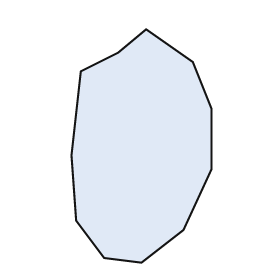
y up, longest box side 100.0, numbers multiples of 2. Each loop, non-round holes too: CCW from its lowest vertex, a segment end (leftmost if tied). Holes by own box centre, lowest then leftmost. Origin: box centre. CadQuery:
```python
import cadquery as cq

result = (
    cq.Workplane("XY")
    .moveTo(0.0, -50.0)
    .lineTo(18.0, -36.0)
    .lineTo(30.0, -10.0)
    .lineTo(30.0, 16.0)
    .lineTo(22.0, 36.0)
    .lineTo(2.0, 50.0)
    .lineTo(-10.0, 40.0)
    .lineTo(-26.0, 32.0)
    .lineTo(-30.0, -4.0)
    .lineTo(-28.0, -32.0)
    .lineTo(-16.0, -48.0)
    .close()
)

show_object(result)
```